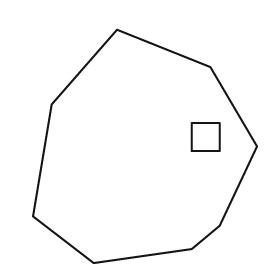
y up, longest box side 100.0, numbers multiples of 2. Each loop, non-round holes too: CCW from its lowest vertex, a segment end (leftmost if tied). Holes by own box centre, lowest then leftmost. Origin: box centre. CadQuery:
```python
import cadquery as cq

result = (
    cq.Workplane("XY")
    .moveTo(-22.0, -50.0)
    .lineTo(20.0, -44.0)
    .lineTo(32.0, -34.0)
    .lineTo(48.0, 0.0)
    .lineTo(28.0, 34.0)
    .lineTo(-12.0, 50.0)
    .lineTo(-40.0, 18.0)
    .lineTo(-48.0, -30.0)
    .close()
    .moveTo(20.0, -2.0)
    .lineTo(32.0, -2.0)
    .lineTo(32.0, 10.0)
    .lineTo(20.0, 10.0)
    .close()
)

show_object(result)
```